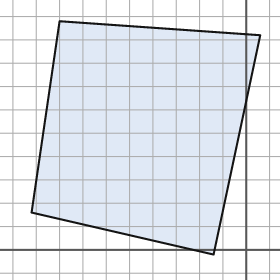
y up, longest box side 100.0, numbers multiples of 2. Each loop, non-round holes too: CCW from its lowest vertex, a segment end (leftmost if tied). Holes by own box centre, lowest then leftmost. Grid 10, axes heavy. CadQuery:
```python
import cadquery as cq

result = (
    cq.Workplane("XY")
    .moveTo(-14.0, -2.0)
    .lineTo(6.0, 92.0)
    .lineTo(-80.0, 98.0)
    .lineTo(-92.0, 16.0)
    .close()
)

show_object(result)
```